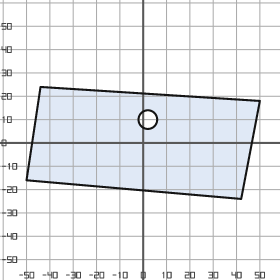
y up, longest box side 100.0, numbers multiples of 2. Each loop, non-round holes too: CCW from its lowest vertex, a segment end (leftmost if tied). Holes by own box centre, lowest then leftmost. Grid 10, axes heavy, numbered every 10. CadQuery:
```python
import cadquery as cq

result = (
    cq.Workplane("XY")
    .moveTo(42.0, -24.0)
    .lineTo(50.0, 18.0)
    .lineTo(-44.0, 24.0)
    .lineTo(-50.0, -16.0)
    .close()
    .moveTo(2.0, 10.0)
    .circle(4.0)
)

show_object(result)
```